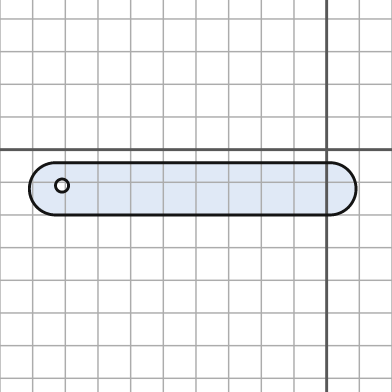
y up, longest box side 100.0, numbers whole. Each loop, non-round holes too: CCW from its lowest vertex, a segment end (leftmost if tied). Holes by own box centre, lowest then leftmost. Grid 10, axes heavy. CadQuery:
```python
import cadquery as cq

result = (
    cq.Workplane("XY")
    .moveTo(-83.0, -20.0)
    .lineTo(1.0, -20.0)
    .threePointArc((9.0, -12.0), (1.0, -4.0))
    .lineTo(-83.0, -4.0)
    .threePointArc((-91.0, -12.0), (-83.0, -20.0))
    .close()
    .moveTo(-81.0, -11.0)
    .circle(2.0)
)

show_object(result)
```